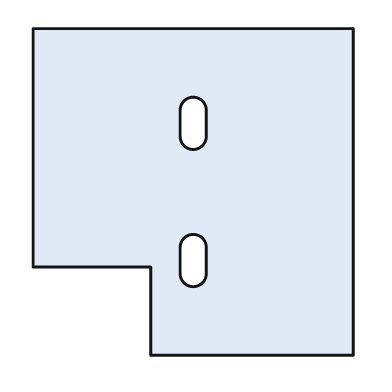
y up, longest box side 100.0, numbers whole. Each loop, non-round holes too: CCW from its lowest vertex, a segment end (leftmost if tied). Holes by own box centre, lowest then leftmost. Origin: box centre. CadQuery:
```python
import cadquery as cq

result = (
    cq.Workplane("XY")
    .moveTo(-13.0, -50.0)
    .lineTo(49.0, -50.0)
    .lineTo(49.0, 50.0)
    .lineTo(-49.0, 50.0)
    .lineTo(-49.0, -23.0)
    .lineTo(-13.0, -23.0)
    .close()
    .moveTo(-4.0, -25.0)
    .threePointArc((0.0, -29.0), (4.0, -25.0))
    .lineTo(4.0, -17.0)
    .threePointArc((0.0, -13.0), (-4.0, -17.0))
    .close()
    .moveTo(-4.0, 17.0)
    .threePointArc((0.0, 13.0), (4.0, 17.0))
    .lineTo(4.0, 25.0)
    .threePointArc((0.0, 29.0), (-4.0, 25.0))
    .close()
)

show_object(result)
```